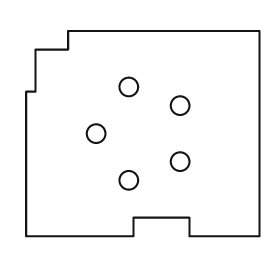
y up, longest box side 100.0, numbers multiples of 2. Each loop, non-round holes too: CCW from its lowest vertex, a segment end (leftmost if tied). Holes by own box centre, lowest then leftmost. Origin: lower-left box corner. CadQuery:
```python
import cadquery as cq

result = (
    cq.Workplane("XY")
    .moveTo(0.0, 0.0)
    .lineTo(46.0, 0.0)
    .lineTo(46.0, 8.0)
    .lineTo(70.0, 8.0)
    .lineTo(70.0, 0.0)
    .lineTo(100.0, 0.0)
    .lineTo(100.0, 88.0)
    .lineTo(18.0, 88.0)
    .lineTo(18.0, 80.0)
    .lineTo(4.0, 80.0)
    .lineTo(4.0, 62.0)
    .lineTo(0.0, 62.0)
    .close()
    .moveTo(44.0, 24.0)
    .circle(4.0)
    .moveTo(66.0, 32.0)
    .circle(4.0)
    .moveTo(30.0, 44.0)
    .circle(4.0)
    .moveTo(66.0, 56.0)
    .circle(4.0)
    .moveTo(44.0, 64.0)
    .circle(4.0)
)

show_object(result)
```